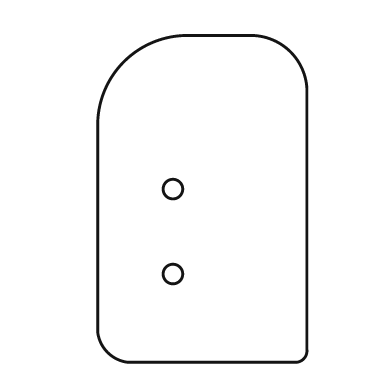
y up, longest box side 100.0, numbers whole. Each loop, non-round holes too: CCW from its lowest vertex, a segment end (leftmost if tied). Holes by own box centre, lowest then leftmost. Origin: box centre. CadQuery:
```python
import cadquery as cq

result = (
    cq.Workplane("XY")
    .moveTo(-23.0, -50.0)
    .lineTo(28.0, -50.0)
    .threePointArc((31.0, -49.0), (32.0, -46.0))
    .lineTo(32.0, 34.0)
    .threePointArc((27.0, 45.0), (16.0, 50.0))
    .lineTo(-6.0, 50.0)
    .threePointArc((-24.0, 42.0), (-32.0, 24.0))
    .lineTo(-32.0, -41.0)
    .threePointArc((-29.0, -47.0), (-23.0, -50.0))
    .close()
    .moveTo(-9.0, -23.0)
    .circle(3.0)
    .moveTo(-9.0, 3.0)
    .circle(3.0)
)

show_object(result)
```